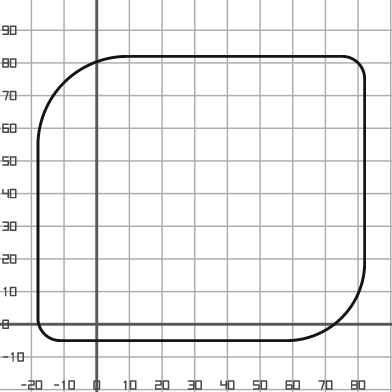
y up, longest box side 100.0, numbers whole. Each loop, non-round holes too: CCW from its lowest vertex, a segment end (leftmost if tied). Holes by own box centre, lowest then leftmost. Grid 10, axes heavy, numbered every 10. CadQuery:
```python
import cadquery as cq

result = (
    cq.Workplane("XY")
    .moveTo(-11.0, -5.0)
    .lineTo(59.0, -5.0)
    .threePointArc((75.0, 2.0), (82.0, 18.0))
    .lineTo(82.0, 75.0)
    .threePointArc((80.0, 80.0), (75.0, 82.0))
    .lineTo(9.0, 82.0)
    .threePointArc((-10.0, 74.0), (-18.0, 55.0))
    .lineTo(-18.0, 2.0)
    .threePointArc((-16.0, -3.0), (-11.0, -5.0))
    .close()
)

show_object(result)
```